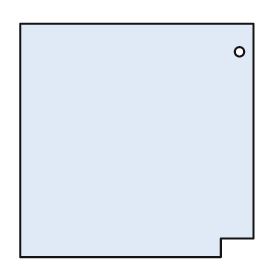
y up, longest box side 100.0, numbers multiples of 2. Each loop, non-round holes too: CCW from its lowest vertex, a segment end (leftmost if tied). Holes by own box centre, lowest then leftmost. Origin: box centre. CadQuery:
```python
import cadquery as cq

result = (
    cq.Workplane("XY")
    .moveTo(-50.0, -50.0)
    .lineTo(36.0, -50.0)
    .lineTo(36.0, -42.0)
    .lineTo(50.0, -42.0)
    .lineTo(50.0, 50.0)
    .lineTo(-50.0, 50.0)
    .close()
    .moveTo(44.0, 38.0)
    .circle(2.0)
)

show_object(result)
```